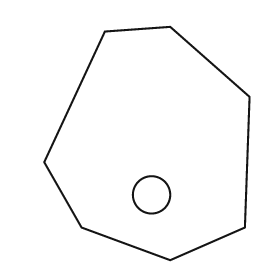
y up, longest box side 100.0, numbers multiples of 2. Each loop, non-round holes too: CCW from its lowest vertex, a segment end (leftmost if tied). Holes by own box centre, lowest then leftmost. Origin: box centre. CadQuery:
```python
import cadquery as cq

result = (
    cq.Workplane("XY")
    .moveTo(10.0, -50.0)
    .lineTo(42.0, -36.0)
    .lineTo(44.0, 20.0)
    .lineTo(10.0, 50.0)
    .lineTo(-18.0, 48.0)
    .lineTo(-44.0, -8.0)
    .lineTo(-28.0, -36.0)
    .close()
    .moveTo(2.0, -22.0)
    .circle(8.0)
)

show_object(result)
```